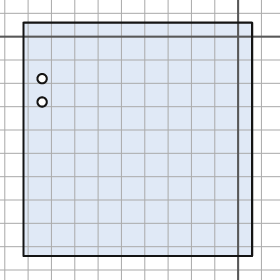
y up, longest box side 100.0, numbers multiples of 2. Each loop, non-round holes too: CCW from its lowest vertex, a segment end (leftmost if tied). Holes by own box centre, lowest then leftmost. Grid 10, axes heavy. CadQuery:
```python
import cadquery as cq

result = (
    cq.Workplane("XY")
    .moveTo(-92.0, -94.0)
    .lineTo(6.0, -94.0)
    .lineTo(6.0, 6.0)
    .lineTo(-92.0, 6.0)
    .close()
    .moveTo(-84.0, -28.0)
    .circle(2.0)
    .moveTo(-84.0, -18.0)
    .circle(2.0)
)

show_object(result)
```